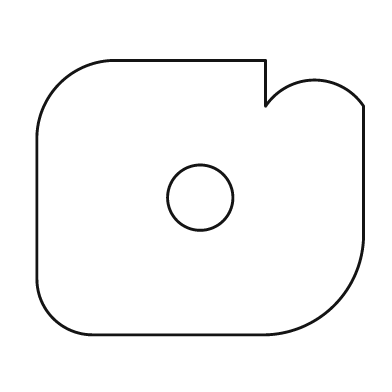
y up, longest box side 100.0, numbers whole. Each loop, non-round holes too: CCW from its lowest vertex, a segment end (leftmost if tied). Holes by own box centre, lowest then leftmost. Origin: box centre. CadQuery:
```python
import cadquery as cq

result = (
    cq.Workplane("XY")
    .moveTo(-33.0, -42.0)
    .lineTo(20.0, -42.0)
    .threePointArc((41.0, -33.0), (50.0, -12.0))
    .lineTo(50.0, 28.0)
    .threePointArc((35.0, 36.0), (20.0, 28.0))
    .lineTo(20.0, 42.0)
    .lineTo(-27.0, 42.0)
    .threePointArc((-43.0, 35.0), (-50.0, 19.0))
    .lineTo(-50.0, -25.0)
    .threePointArc((-45.0, -37.0), (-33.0, -42.0))
    .close()
    .moveTo(0.0, 0.0)
    .circle(10.0)
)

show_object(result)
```